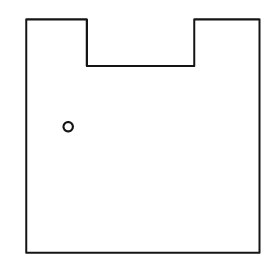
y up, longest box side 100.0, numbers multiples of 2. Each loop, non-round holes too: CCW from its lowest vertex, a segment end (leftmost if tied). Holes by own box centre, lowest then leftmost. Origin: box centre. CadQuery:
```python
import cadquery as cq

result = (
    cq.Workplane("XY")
    .moveTo(-50.0, -50.0)
    .lineTo(50.0, -50.0)
    .lineTo(50.0, 50.0)
    .lineTo(22.0, 50.0)
    .lineTo(22.0, 30.0)
    .lineTo(-24.0, 30.0)
    .lineTo(-24.0, 50.0)
    .lineTo(-50.0, 50.0)
    .close()
    .moveTo(-32.0, 4.0)
    .circle(2.0)
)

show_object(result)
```